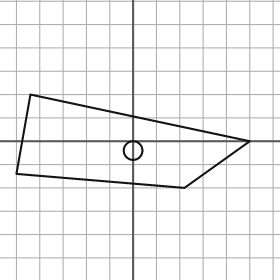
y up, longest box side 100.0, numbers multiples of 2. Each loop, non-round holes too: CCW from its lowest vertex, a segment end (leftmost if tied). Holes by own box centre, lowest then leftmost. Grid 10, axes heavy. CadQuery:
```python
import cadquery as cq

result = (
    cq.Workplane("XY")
    .moveTo(22.0, -20.0)
    .lineTo(50.0, 0.0)
    .lineTo(-44.0, 20.0)
    .lineTo(-50.0, -14.0)
    .close()
    .moveTo(0.0, -4.0)
    .circle(4.0)
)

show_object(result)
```